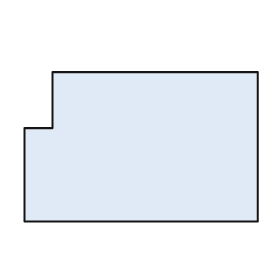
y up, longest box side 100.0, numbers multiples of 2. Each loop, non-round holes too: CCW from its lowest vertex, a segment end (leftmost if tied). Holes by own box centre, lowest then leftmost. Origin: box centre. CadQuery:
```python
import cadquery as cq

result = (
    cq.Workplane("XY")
    .moveTo(-50.0, -32.0)
    .lineTo(50.0, -32.0)
    .lineTo(50.0, 32.0)
    .lineTo(-38.0, 32.0)
    .lineTo(-38.0, 8.0)
    .lineTo(-50.0, 8.0)
    .close()
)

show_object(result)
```